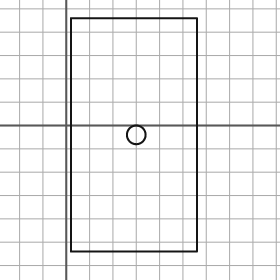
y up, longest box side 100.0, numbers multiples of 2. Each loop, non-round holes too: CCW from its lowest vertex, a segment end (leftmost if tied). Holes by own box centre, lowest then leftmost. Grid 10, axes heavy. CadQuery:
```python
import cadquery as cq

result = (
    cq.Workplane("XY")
    .moveTo(2.0, -54.0)
    .lineTo(56.0, -54.0)
    .lineTo(56.0, 46.0)
    .lineTo(2.0, 46.0)
    .close()
    .moveTo(30.0, -4.0)
    .circle(4.0)
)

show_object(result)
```